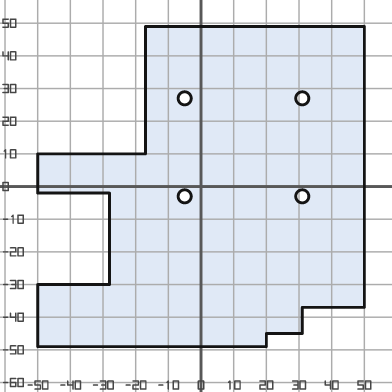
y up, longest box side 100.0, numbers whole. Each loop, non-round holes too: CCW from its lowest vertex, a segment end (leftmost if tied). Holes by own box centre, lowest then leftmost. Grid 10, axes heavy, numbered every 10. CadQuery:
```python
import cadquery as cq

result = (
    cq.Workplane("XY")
    .moveTo(-50.0, -49.0)
    .lineTo(20.0, -49.0)
    .lineTo(20.0, -45.0)
    .lineTo(31.0, -45.0)
    .lineTo(31.0, -37.0)
    .lineTo(50.0, -37.0)
    .lineTo(50.0, 49.0)
    .lineTo(-17.0, 49.0)
    .lineTo(-17.0, 10.0)
    .lineTo(-50.0, 10.0)
    .lineTo(-50.0, -2.0)
    .lineTo(-28.0, -2.0)
    .lineTo(-28.0, -30.0)
    .lineTo(-50.0, -30.0)
    .close()
    .moveTo(-5.0, -3.0)
    .circle(2.0)
    .moveTo(31.0, -3.0)
    .circle(2.0)
    .moveTo(-5.0, 27.0)
    .circle(2.0)
    .moveTo(31.0, 27.0)
    .circle(2.0)
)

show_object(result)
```